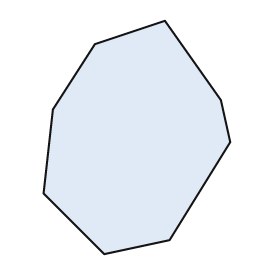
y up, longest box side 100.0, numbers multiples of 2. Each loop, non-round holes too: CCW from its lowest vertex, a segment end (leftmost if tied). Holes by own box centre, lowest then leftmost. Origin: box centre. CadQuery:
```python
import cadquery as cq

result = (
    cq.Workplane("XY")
    .moveTo(-14.0, -50.0)
    .lineTo(14.0, -44.0)
    .lineTo(40.0, -2.0)
    .lineTo(36.0, 16.0)
    .lineTo(12.0, 50.0)
    .lineTo(-18.0, 40.0)
    .lineTo(-36.0, 12.0)
    .lineTo(-40.0, -24.0)
    .close()
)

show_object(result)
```